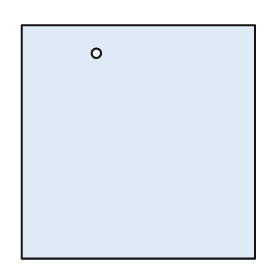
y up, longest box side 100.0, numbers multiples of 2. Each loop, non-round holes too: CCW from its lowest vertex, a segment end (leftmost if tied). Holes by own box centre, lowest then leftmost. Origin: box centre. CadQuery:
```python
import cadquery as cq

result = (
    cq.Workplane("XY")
    .moveTo(-50.0, -50.0)
    .lineTo(50.0, -50.0)
    .lineTo(50.0, 50.0)
    .lineTo(-50.0, 50.0)
    .close()
    .moveTo(-18.0, 38.0)
    .circle(2.0)
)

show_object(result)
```